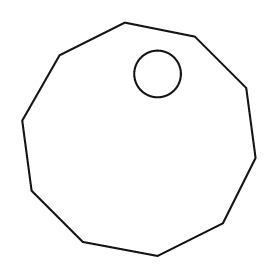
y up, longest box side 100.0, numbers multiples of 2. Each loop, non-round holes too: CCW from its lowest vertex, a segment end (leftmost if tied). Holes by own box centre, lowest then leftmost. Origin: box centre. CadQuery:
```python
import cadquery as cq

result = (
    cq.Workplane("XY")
    .moveTo(8.0, -50.0)
    .lineTo(36.0, -36.0)
    .lineTo(50.0, -8.0)
    .lineTo(46.0, 22.0)
    .lineTo(24.0, 44.0)
    .lineTo(-6.0, 50.0)
    .lineTo(-34.0, 36.0)
    .lineTo(-50.0, 8.0)
    .lineTo(-46.0, -22.0)
    .lineTo(-24.0, -44.0)
    .close()
    .moveTo(8.0, 28.0)
    .circle(10.0)
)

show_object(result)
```